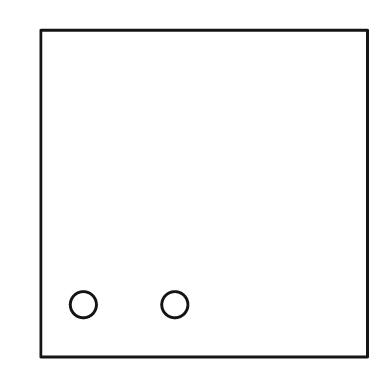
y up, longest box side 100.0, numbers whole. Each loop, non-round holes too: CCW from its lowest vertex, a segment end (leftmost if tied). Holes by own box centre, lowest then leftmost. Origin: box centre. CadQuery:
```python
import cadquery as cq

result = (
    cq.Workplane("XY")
    .moveTo(-50.0, -50.0)
    .lineTo(50.0, -50.0)
    .lineTo(50.0, 50.0)
    .lineTo(-50.0, 50.0)
    .close()
    .moveTo(-37.0, -34.0)
    .circle(4.0)
    .moveTo(-9.0, -34.0)
    .circle(4.0)
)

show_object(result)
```